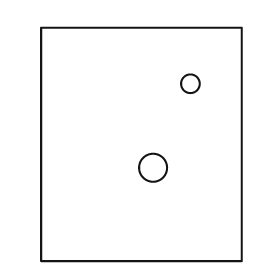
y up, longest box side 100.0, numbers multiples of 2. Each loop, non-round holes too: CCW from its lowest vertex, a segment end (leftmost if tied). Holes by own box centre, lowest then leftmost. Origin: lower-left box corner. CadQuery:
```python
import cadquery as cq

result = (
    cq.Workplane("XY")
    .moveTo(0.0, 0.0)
    .lineTo(86.0, 0.0)
    .lineTo(86.0, 100.0)
    .lineTo(0.0, 100.0)
    .close()
    .moveTo(48.0, 40.0)
    .circle(6.0)
    .moveTo(64.0, 76.0)
    .circle(4.0)
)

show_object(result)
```